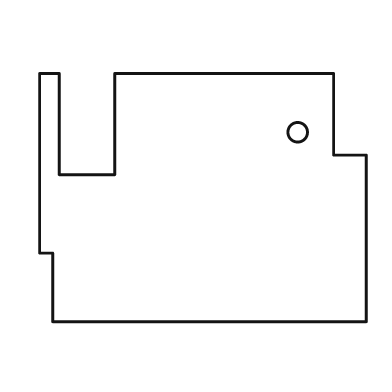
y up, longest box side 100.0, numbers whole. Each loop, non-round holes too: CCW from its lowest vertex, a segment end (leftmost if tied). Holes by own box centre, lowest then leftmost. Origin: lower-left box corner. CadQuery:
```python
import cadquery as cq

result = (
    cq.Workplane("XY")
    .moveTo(4.0, 0.0)
    .lineTo(100.0, 0.0)
    .lineTo(100.0, 51.0)
    .lineTo(90.0, 51.0)
    .lineTo(90.0, 76.0)
    .lineTo(23.0, 76.0)
    .lineTo(23.0, 45.0)
    .lineTo(6.0, 45.0)
    .lineTo(6.0, 76.0)
    .lineTo(0.0, 76.0)
    .lineTo(0.0, 21.0)
    .lineTo(4.0, 21.0)
    .close()
    .moveTo(79.0, 58.0)
    .circle(3.0)
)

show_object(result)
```